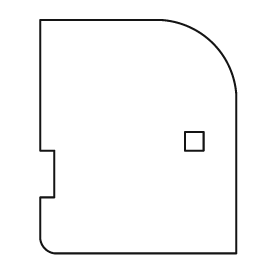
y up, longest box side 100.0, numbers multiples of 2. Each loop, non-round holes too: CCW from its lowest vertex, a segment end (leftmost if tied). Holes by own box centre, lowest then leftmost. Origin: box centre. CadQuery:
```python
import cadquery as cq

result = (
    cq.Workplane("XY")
    .moveTo(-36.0, -50.0)
    .lineTo(42.0, -50.0)
    .lineTo(42.0, 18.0)
    .threePointArc((32.0, 40.0), (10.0, 50.0))
    .lineTo(-42.0, 50.0)
    .lineTo(-42.0, -6.0)
    .lineTo(-36.0, -6.0)
    .lineTo(-36.0, -26.0)
    .lineTo(-42.0, -26.0)
    .lineTo(-42.0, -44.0)
    .threePointArc((-40.0, -48.0), (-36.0, -50.0))
    .close()
    .moveTo(20.0, -6.0)
    .lineTo(28.0, -6.0)
    .lineTo(28.0, 2.0)
    .lineTo(20.0, 2.0)
    .close()
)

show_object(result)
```